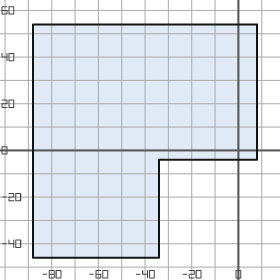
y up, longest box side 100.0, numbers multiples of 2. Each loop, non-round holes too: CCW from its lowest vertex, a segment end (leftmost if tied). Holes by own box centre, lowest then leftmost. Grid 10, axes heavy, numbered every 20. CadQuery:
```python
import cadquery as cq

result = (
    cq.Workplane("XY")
    .moveTo(-88.0, -46.0)
    .lineTo(-34.0, -46.0)
    .lineTo(-34.0, -4.0)
    .lineTo(8.0, -4.0)
    .lineTo(8.0, 54.0)
    .lineTo(-88.0, 54.0)
    .close()
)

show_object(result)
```